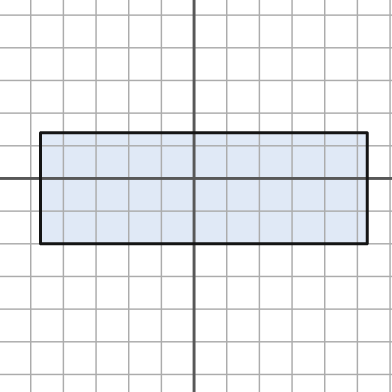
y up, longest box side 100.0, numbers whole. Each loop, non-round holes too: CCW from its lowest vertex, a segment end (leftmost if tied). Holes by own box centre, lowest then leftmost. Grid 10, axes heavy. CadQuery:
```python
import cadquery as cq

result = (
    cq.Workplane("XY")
    .moveTo(-47.0, -20.0)
    .lineTo(53.0, -20.0)
    .lineTo(53.0, 14.0)
    .lineTo(-47.0, 14.0)
    .close()
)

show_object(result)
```